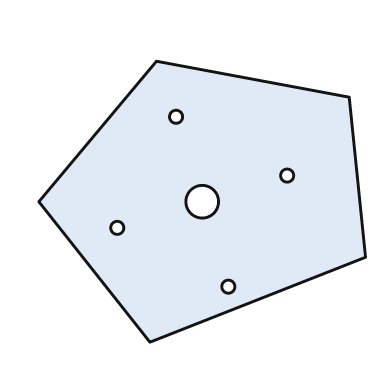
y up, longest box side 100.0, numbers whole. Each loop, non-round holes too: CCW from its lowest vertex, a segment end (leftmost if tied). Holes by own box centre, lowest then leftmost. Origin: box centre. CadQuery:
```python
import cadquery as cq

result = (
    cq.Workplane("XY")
    .moveTo(-16.0, -43.0)
    .lineTo(50.0, -17.0)
    .lineTo(45.0, 32.0)
    .lineTo(-14.0, 43.0)
    .lineTo(-50.0, 0.0)
    .close()
    .moveTo(8.0, -26.0)
    .circle(2.0)
    .moveTo(-26.0, -8.0)
    .circle(2.0)
    .moveTo(0.0, 0.0)
    .circle(5.0)
    .moveTo(26.0, 8.0)
    .circle(2.0)
    .moveTo(-8.0, 26.0)
    .circle(2.0)
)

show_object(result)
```